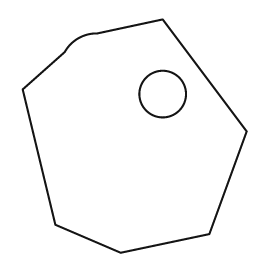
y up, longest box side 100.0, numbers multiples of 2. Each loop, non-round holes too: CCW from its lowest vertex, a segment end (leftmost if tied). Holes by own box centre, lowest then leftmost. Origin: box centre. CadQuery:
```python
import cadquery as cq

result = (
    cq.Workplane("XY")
    .moveTo(-6.0, -50.0)
    .lineTo(32.0, -42.0)
    .lineTo(48.0, 2.0)
    .lineTo(12.0, 50.0)
    .lineTo(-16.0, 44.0)
    .threePointArc((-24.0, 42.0), (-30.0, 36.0))
    .lineTo(-48.0, 20.0)
    .lineTo(-34.0, -38.0)
    .close()
    .moveTo(12.0, 18.0)
    .circle(10.0)
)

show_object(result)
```